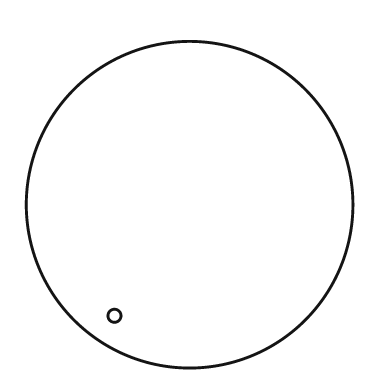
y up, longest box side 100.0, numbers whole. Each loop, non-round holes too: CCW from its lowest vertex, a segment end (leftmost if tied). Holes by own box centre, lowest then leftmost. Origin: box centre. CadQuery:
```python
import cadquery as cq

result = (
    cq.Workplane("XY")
    .moveTo(0.0, 0.0)
    .circle(50.0)
    .moveTo(-23.0, -34.0)
    .circle(2.0)
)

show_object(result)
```